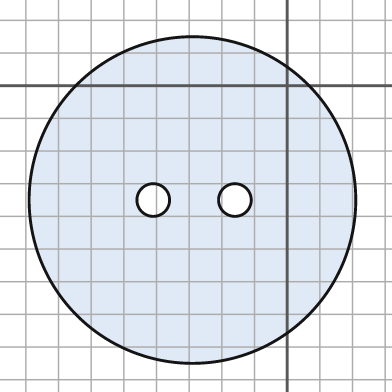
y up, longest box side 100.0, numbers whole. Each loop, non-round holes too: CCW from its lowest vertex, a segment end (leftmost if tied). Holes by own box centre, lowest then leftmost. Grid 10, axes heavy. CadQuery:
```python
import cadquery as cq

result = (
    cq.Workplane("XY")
    .moveTo(-29.0, -35.0)
    .circle(50.0)
    .moveTo(-41.0, -35.0)
    .circle(5.0)
    .moveTo(-16.0, -35.0)
    .circle(5.0)
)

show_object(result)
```